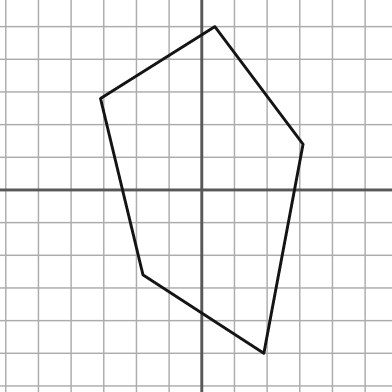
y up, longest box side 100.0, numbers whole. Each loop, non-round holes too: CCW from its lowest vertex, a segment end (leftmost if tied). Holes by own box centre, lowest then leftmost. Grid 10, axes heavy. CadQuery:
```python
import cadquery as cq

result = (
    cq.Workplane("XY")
    .moveTo(19.0, -50.0)
    .lineTo(31.0, 14.0)
    .lineTo(4.0, 50.0)
    .lineTo(-31.0, 28.0)
    .lineTo(-18.0, -26.0)
    .close()
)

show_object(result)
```